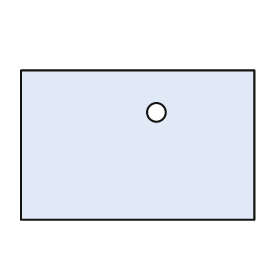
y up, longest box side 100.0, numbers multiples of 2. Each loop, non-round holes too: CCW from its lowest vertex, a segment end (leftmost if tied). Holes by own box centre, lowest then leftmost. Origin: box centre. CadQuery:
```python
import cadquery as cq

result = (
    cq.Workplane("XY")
    .moveTo(-50.0, -32.0)
    .lineTo(50.0, -32.0)
    .lineTo(50.0, 32.0)
    .lineTo(-50.0, 32.0)
    .close()
    .moveTo(8.0, 14.0)
    .circle(4.0)
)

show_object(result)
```